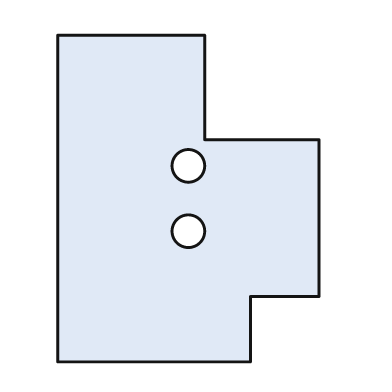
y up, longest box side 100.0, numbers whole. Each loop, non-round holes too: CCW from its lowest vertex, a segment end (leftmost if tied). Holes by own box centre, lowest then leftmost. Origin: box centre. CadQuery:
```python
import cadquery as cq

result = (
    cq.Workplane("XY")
    .moveTo(-40.0, -50.0)
    .lineTo(19.0, -50.0)
    .lineTo(19.0, -30.0)
    .lineTo(40.0, -30.0)
    .lineTo(40.0, 18.0)
    .lineTo(5.0, 18.0)
    .lineTo(5.0, 50.0)
    .lineTo(-40.0, 50.0)
    .close()
    .moveTo(0.0, -10.0)
    .circle(5.0)
    .moveTo(0.0, 10.0)
    .circle(5.0)
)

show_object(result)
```